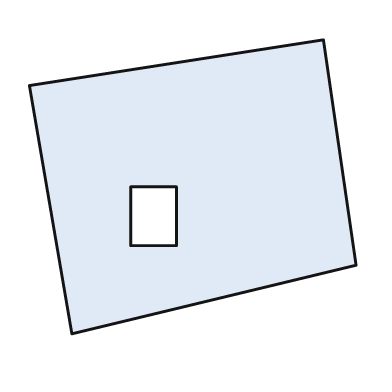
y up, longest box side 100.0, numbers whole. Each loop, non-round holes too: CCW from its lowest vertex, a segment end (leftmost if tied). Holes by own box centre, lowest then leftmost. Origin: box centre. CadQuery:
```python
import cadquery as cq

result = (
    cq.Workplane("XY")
    .moveTo(-37.0, -45.0)
    .lineTo(50.0, -24.0)
    .lineTo(40.0, 45.0)
    .lineTo(-50.0, 31.0)
    .close()
    .moveTo(-19.0, -18.0)
    .lineTo(-5.0, -18.0)
    .lineTo(-5.0, 0.0)
    .lineTo(-19.0, 0.0)
    .close()
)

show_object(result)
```